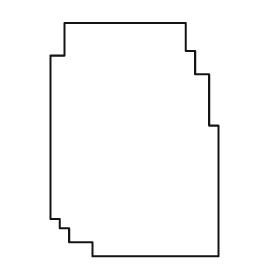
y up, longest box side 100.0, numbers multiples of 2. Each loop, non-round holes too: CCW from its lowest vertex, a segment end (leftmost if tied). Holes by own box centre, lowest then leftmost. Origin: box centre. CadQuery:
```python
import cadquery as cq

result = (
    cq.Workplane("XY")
    .moveTo(-18.0, -50.0)
    .lineTo(36.0, -50.0)
    .lineTo(36.0, 6.0)
    .lineTo(32.0, 6.0)
    .lineTo(32.0, 28.0)
    .lineTo(26.0, 28.0)
    .lineTo(26.0, 38.0)
    .lineTo(22.0, 38.0)
    .lineTo(22.0, 50.0)
    .lineTo(-30.0, 50.0)
    .lineTo(-30.0, 36.0)
    .lineTo(-36.0, 36.0)
    .lineTo(-36.0, -34.0)
    .lineTo(-32.0, -34.0)
    .lineTo(-32.0, -38.0)
    .lineTo(-28.0, -38.0)
    .lineTo(-28.0, -44.0)
    .lineTo(-18.0, -44.0)
    .close()
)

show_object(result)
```